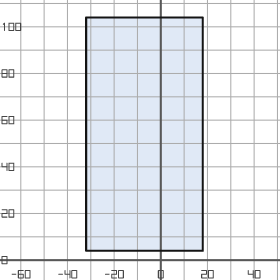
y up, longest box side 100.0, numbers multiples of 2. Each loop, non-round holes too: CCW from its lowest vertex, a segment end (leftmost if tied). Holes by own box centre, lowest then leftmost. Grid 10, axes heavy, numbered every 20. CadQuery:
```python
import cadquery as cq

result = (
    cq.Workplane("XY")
    .moveTo(-32.0, 4.0)
    .lineTo(18.0, 4.0)
    .lineTo(18.0, 104.0)
    .lineTo(-32.0, 104.0)
    .close()
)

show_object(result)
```